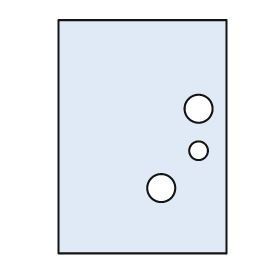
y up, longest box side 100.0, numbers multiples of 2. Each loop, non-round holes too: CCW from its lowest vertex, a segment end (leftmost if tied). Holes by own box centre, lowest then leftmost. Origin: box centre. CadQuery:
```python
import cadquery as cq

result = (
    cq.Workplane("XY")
    .moveTo(-36.0, -50.0)
    .lineTo(36.0, -50.0)
    .lineTo(36.0, 50.0)
    .lineTo(-36.0, 50.0)
    .close()
    .moveTo(8.0, -22.0)
    .circle(6.0)
    .moveTo(24.0, -6.0)
    .circle(4.0)
    .moveTo(24.0, 12.0)
    .circle(6.0)
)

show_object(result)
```